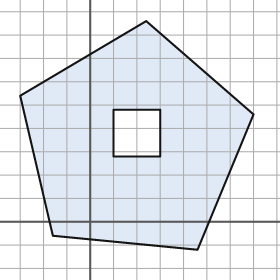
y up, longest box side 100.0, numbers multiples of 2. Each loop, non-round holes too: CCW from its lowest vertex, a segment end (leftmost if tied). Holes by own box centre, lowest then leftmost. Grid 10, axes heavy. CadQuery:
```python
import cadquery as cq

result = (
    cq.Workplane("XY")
    .moveTo(46.0, -12.0)
    .lineTo(70.0, 46.0)
    .lineTo(24.0, 86.0)
    .lineTo(-30.0, 54.0)
    .lineTo(-16.0, -6.0)
    .close()
    .moveTo(10.0, 28.0)
    .lineTo(30.0, 28.0)
    .lineTo(30.0, 48.0)
    .lineTo(10.0, 48.0)
    .close()
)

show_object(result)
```